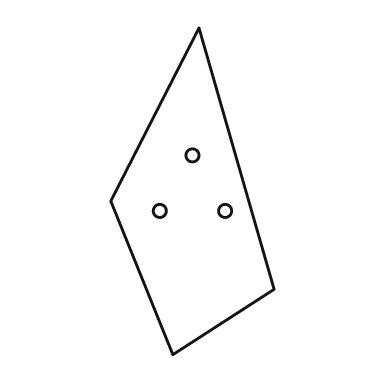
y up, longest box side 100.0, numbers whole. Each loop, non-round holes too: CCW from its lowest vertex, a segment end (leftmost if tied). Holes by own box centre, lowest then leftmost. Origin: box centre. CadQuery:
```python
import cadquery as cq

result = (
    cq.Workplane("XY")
    .moveTo(-6.0, -50.0)
    .lineTo(25.0, -30.0)
    .lineTo(2.0, 50.0)
    .lineTo(-25.0, -3.0)
    .close()
    .moveTo(-10.0, -6.0)
    .circle(2.0)
    .moveTo(10.0, -6.0)
    .circle(2.0)
    .moveTo(0.0, 11.0)
    .circle(2.0)
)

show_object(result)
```